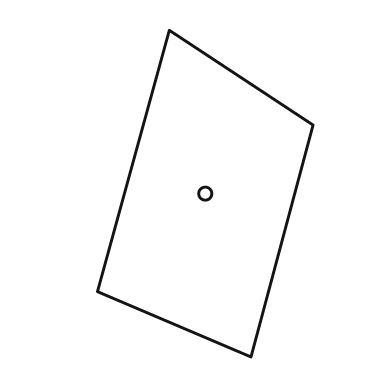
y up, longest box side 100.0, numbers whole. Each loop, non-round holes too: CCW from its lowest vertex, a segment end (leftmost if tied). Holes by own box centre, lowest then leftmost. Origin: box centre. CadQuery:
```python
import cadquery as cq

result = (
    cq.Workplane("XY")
    .moveTo(14.0, -50.0)
    .lineTo(33.0, 21.0)
    .lineTo(-11.0, 50.0)
    .lineTo(-33.0, -30.0)
    .close()
    .moveTo(0.0, 0.0)
    .circle(2.0)
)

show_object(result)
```